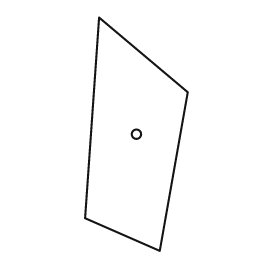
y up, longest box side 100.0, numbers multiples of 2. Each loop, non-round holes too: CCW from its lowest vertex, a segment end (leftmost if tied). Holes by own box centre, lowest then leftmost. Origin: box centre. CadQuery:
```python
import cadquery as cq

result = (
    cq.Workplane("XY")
    .moveTo(10.0, -50.0)
    .lineTo(22.0, 18.0)
    .lineTo(-16.0, 50.0)
    .lineTo(-22.0, -36.0)
    .close()
    .moveTo(0.0, 0.0)
    .circle(2.0)
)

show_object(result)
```